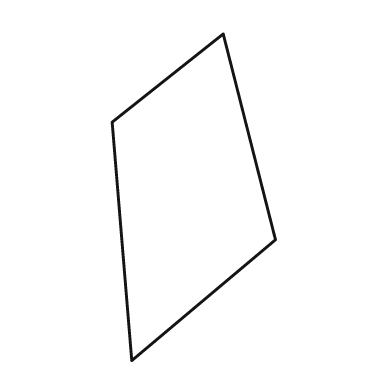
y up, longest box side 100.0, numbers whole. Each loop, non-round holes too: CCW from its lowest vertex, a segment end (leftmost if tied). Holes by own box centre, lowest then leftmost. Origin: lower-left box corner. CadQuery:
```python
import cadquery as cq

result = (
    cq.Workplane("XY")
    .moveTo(6.0, 0.0)
    .lineTo(50.0, 37.0)
    .lineTo(34.0, 100.0)
    .lineTo(0.0, 73.0)
    .close()
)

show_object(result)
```